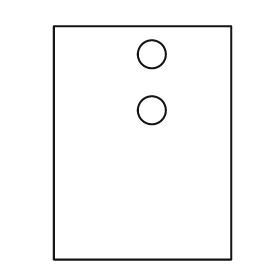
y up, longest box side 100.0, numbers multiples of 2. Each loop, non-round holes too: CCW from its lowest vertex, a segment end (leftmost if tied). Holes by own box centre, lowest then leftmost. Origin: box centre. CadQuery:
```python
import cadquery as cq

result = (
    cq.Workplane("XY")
    .moveTo(-38.0, -50.0)
    .lineTo(38.0, -50.0)
    .lineTo(38.0, 50.0)
    .lineTo(-38.0, 50.0)
    .close()
    .moveTo(4.0, 14.0)
    .circle(6.0)
    .moveTo(4.0, 38.0)
    .circle(6.0)
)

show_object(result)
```